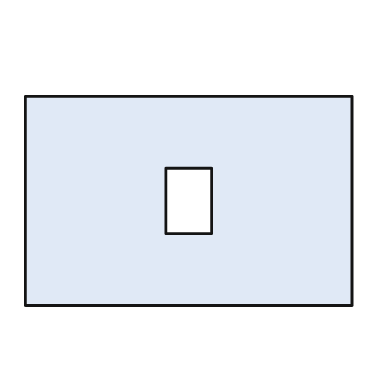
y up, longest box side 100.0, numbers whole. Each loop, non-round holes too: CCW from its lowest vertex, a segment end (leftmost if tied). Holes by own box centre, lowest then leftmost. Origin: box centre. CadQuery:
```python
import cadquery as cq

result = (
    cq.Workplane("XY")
    .moveTo(-50.0, -32.0)
    .lineTo(50.0, -32.0)
    .lineTo(50.0, 32.0)
    .lineTo(-50.0, 32.0)
    .close()
    .moveTo(-7.0, -10.0)
    .lineTo(7.0, -10.0)
    .lineTo(7.0, 10.0)
    .lineTo(-7.0, 10.0)
    .close()
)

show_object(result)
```